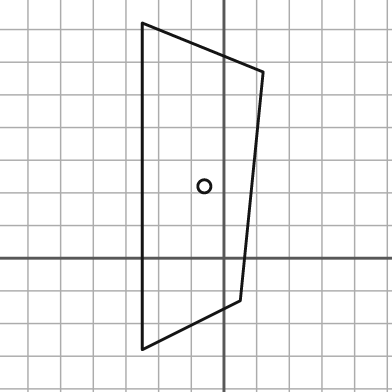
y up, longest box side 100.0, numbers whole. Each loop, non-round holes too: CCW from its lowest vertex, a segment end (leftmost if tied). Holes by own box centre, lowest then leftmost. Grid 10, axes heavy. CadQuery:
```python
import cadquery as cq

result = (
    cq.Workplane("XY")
    .moveTo(-25.0, -28.0)
    .lineTo(5.0, -13.0)
    .lineTo(12.0, 57.0)
    .lineTo(-25.0, 72.0)
    .close()
    .moveTo(-6.0, 22.0)
    .circle(2.0)
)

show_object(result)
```